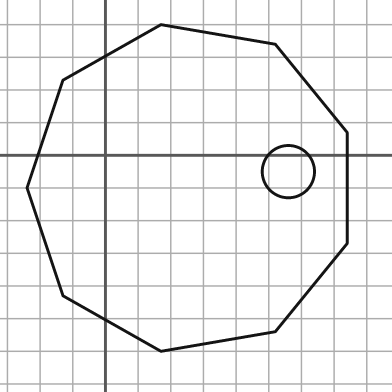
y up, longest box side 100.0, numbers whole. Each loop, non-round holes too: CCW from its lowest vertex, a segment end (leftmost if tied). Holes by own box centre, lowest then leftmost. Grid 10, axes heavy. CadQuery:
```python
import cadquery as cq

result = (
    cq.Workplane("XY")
    .moveTo(17.0, -60.0)
    .lineTo(52.0, -54.0)
    .lineTo(74.0, -27.0)
    .lineTo(74.0, 7.0)
    .lineTo(52.0, 34.0)
    .lineTo(17.0, 40.0)
    .lineTo(-13.0, 23.0)
    .lineTo(-24.0, -10.0)
    .lineTo(-13.0, -43.0)
    .close()
    .moveTo(56.0, -5.0)
    .circle(8.0)
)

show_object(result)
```